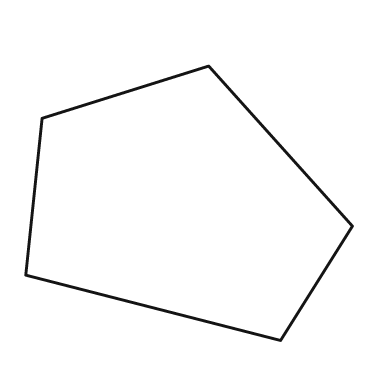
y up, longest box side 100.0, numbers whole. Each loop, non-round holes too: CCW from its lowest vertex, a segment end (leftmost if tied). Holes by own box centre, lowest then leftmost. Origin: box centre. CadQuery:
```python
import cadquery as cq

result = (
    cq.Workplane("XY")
    .moveTo(28.0, -42.0)
    .lineTo(50.0, -7.0)
    .lineTo(6.0, 42.0)
    .lineTo(-45.0, 26.0)
    .lineTo(-50.0, -22.0)
    .close()
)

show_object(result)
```